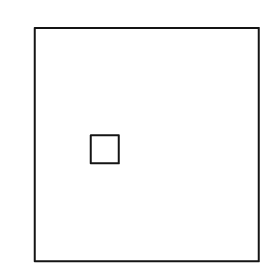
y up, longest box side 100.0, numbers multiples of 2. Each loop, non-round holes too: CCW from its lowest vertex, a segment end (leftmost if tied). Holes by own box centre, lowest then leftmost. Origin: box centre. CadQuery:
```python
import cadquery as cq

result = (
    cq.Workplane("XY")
    .moveTo(-48.0, -50.0)
    .lineTo(48.0, -50.0)
    .lineTo(48.0, 50.0)
    .lineTo(-48.0, 50.0)
    .close()
    .moveTo(-24.0, -8.0)
    .lineTo(-12.0, -8.0)
    .lineTo(-12.0, 4.0)
    .lineTo(-24.0, 4.0)
    .close()
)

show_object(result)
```